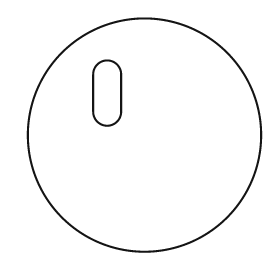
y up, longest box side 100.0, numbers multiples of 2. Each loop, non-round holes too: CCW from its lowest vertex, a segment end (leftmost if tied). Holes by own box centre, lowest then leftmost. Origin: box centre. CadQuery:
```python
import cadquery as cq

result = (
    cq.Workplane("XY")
    .moveTo(0.0, 0.0)
    .circle(50.0)
    .moveTo(-22.0, 10.0)
    .threePointArc((-16.0, 4.0), (-10.0, 10.0))
    .lineTo(-10.0, 26.0)
    .threePointArc((-16.0, 32.0), (-22.0, 26.0))
    .close()
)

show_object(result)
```